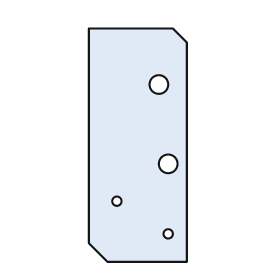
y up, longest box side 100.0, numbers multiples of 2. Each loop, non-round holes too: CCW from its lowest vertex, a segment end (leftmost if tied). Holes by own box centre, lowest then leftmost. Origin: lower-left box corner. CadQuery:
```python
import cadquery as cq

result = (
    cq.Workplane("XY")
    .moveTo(8.0, 0.0)
    .lineTo(42.0, 0.0)
    .lineTo(42.0, 94.0)
    .lineTo(36.0, 100.0)
    .lineTo(0.0, 100.0)
    .lineTo(0.0, 8.0)
    .close()
    .moveTo(34.0, 12.0)
    .circle(2.0)
    .moveTo(12.0, 26.0)
    .circle(2.0)
    .moveTo(34.0, 42.0)
    .circle(4.0)
    .moveTo(30.0, 76.0)
    .circle(4.0)
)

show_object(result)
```